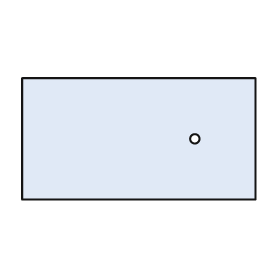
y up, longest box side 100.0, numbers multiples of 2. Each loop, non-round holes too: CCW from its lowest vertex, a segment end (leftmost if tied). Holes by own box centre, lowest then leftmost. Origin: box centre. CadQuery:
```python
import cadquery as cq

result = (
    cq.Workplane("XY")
    .moveTo(-50.0, -26.0)
    .lineTo(50.0, -26.0)
    .lineTo(50.0, 26.0)
    .lineTo(-50.0, 26.0)
    .close()
    .moveTo(24.0, 0.0)
    .circle(2.0)
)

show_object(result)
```